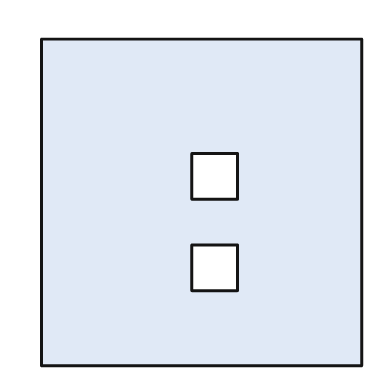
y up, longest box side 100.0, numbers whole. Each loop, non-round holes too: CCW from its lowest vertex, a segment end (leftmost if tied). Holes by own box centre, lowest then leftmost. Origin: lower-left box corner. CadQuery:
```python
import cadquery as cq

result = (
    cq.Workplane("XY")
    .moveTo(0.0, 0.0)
    .lineTo(98.0, 0.0)
    .lineTo(98.0, 100.0)
    .lineTo(0.0, 100.0)
    .close()
    .moveTo(46.0, 23.0)
    .lineTo(60.0, 23.0)
    .lineTo(60.0, 37.0)
    .lineTo(46.0, 37.0)
    .close()
    .moveTo(46.0, 51.0)
    .lineTo(60.0, 51.0)
    .lineTo(60.0, 65.0)
    .lineTo(46.0, 65.0)
    .close()
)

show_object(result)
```